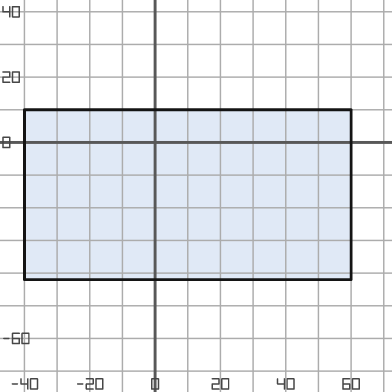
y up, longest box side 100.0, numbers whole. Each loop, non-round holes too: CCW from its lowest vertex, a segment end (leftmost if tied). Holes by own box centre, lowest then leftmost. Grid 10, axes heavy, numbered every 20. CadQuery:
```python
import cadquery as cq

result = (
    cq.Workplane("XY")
    .moveTo(-40.0, -42.0)
    .lineTo(60.0, -42.0)
    .lineTo(60.0, 10.0)
    .lineTo(-40.0, 10.0)
    .close()
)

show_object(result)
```